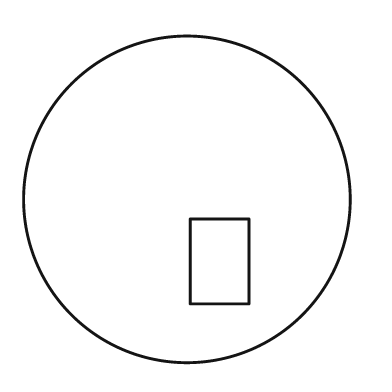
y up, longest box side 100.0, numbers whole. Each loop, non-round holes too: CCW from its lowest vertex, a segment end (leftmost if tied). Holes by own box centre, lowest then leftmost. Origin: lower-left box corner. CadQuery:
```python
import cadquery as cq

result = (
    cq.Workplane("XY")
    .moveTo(50.0, 50.0)
    .circle(50.0)
    .moveTo(51.0, 18.0)
    .lineTo(69.0, 18.0)
    .lineTo(69.0, 44.0)
    .lineTo(51.0, 44.0)
    .close()
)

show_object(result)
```